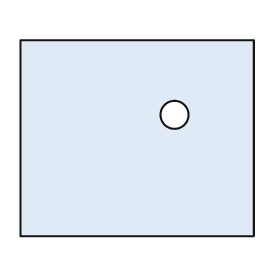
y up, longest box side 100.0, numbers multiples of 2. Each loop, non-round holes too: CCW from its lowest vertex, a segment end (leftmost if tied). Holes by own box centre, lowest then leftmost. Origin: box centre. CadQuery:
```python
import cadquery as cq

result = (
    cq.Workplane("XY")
    .moveTo(-50.0, -42.0)
    .lineTo(50.0, -42.0)
    .lineTo(50.0, 42.0)
    .lineTo(-50.0, 42.0)
    .close()
    .moveTo(16.0, 10.0)
    .circle(6.0)
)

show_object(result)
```